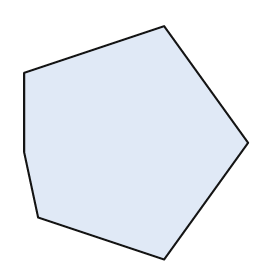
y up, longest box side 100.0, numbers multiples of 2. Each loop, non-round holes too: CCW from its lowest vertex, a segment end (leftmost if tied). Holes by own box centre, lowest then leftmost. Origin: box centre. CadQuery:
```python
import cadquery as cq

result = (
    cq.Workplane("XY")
    .moveTo(12.0, -50.0)
    .lineTo(48.0, 0.0)
    .lineTo(12.0, 50.0)
    .lineTo(-48.0, 30.0)
    .lineTo(-48.0, -4.0)
    .lineTo(-42.0, -32.0)
    .close()
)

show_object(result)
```